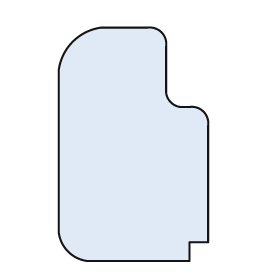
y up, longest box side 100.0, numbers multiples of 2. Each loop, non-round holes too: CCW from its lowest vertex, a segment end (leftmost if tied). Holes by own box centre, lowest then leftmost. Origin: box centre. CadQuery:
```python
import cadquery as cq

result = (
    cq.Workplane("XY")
    .moveTo(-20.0, -50.0)
    .lineTo(24.0, -50.0)
    .lineTo(24.0, -42.0)
    .lineTo(32.0, -42.0)
    .lineTo(32.0, 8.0)
    .threePointArc((30.0, 14.0), (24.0, 16.0))
    .lineTo(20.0, 16.0)
    .threePointArc((16.0, 18.0), (14.0, 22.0))
    .lineTo(14.0, 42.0)
    .threePointArc((12.0, 48.0), (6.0, 50.0))
    .lineTo(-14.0, 50.0)
    .threePointArc((-26.0, 44.0), (-32.0, 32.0))
    .lineTo(-32.0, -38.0)
    .threePointArc((-28.0, -46.0), (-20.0, -50.0))
    .close()
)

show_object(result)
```